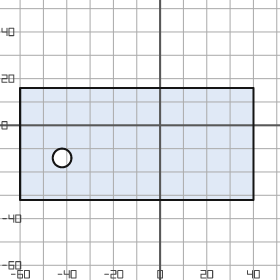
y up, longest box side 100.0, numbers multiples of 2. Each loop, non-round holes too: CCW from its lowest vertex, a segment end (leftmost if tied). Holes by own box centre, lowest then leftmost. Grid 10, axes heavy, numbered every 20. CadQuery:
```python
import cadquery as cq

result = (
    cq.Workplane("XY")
    .moveTo(-60.0, -32.0)
    .lineTo(40.0, -32.0)
    .lineTo(40.0, 16.0)
    .lineTo(-60.0, 16.0)
    .close()
    .moveTo(-42.0, -14.0)
    .circle(4.0)
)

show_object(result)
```